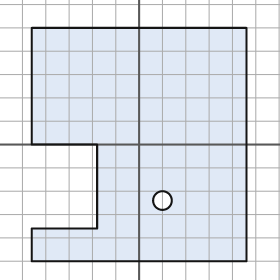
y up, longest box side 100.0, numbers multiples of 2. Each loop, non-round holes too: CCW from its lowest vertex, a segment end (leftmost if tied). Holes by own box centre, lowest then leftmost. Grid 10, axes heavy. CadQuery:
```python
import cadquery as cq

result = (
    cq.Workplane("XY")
    .moveTo(-46.0, -50.0)
    .lineTo(46.0, -50.0)
    .lineTo(46.0, 50.0)
    .lineTo(-46.0, 50.0)
    .lineTo(-46.0, 0.0)
    .lineTo(-18.0, 0.0)
    .lineTo(-18.0, -36.0)
    .lineTo(-46.0, -36.0)
    .close()
    .moveTo(10.0, -24.0)
    .circle(4.0)
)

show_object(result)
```